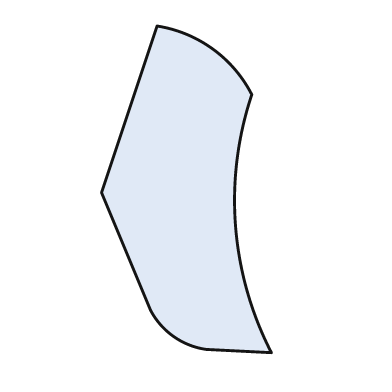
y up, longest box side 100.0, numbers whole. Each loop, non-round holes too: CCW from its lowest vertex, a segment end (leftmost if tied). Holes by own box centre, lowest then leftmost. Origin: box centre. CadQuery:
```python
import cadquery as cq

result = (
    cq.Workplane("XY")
    .moveTo(26.0, -50.0)
    .threePointArc((15.0, -11.0), (20.0, 29.0))
    .threePointArc((8.0, 43.0), (-9.0, 50.0))
    .lineTo(-26.0, -1.0)
    .lineTo(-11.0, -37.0)
    .threePointArc((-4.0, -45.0), (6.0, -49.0))
    .close()
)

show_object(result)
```